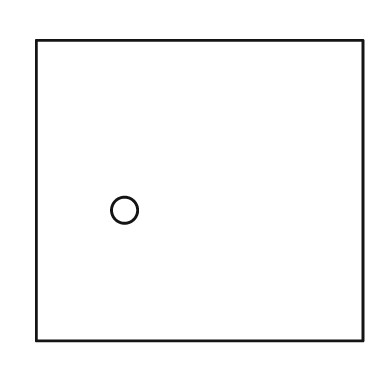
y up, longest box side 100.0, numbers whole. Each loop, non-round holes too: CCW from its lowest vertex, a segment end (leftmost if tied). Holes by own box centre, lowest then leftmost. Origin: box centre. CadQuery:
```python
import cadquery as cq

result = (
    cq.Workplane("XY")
    .moveTo(-50.0, -46.0)
    .lineTo(50.0, -46.0)
    .lineTo(50.0, 46.0)
    .lineTo(-50.0, 46.0)
    .close()
    .moveTo(-23.0, -6.0)
    .circle(4.0)
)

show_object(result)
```